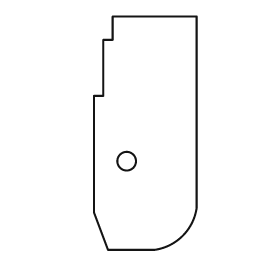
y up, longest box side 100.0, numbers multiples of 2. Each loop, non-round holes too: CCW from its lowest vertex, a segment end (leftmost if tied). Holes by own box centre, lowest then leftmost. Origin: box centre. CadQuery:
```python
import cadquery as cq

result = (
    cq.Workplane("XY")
    .moveTo(-16.0, -50.0)
    .lineTo(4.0, -50.0)
    .threePointArc((16.0, -44.0), (22.0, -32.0))
    .lineTo(22.0, 50.0)
    .lineTo(-14.0, 50.0)
    .lineTo(-14.0, 40.0)
    .lineTo(-18.0, 40.0)
    .lineTo(-18.0, 16.0)
    .lineTo(-22.0, 16.0)
    .lineTo(-22.0, -34.0)
    .close()
    .moveTo(-8.0, -12.0)
    .circle(4.0)
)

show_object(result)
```